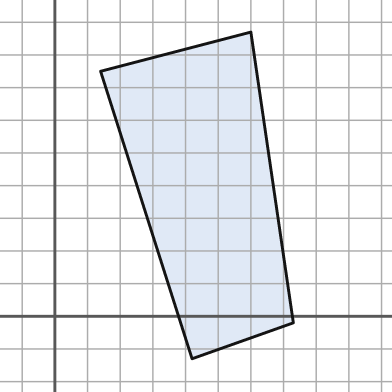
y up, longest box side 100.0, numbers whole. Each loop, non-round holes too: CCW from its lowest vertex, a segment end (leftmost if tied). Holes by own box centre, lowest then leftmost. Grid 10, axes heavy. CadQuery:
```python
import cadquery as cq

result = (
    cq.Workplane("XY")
    .moveTo(42.0, -13.0)
    .lineTo(73.0, -2.0)
    .lineTo(60.0, 87.0)
    .lineTo(14.0, 75.0)
    .close()
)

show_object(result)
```